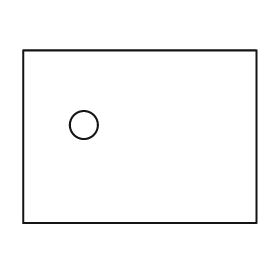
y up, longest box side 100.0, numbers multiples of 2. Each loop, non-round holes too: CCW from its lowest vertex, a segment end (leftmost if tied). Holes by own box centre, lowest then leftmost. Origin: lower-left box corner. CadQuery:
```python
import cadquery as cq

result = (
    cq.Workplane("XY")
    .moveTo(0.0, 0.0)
    .lineTo(100.0, 0.0)
    .lineTo(100.0, 74.0)
    .lineTo(0.0, 74.0)
    .close()
    .moveTo(26.0, 42.0)
    .circle(6.0)
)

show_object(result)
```